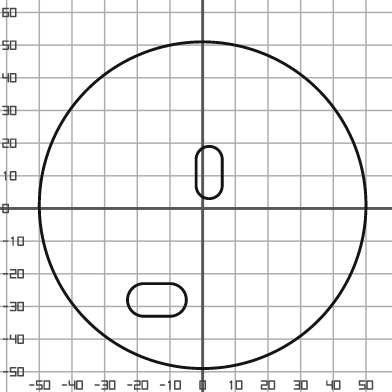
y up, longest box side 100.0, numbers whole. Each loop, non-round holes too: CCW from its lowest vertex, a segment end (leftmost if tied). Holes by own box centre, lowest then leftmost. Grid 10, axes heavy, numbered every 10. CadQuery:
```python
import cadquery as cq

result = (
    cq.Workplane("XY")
    .moveTo(0.0, 1.0)
    .circle(50.0)
    .moveTo(-18.0, -33.0)
    .lineTo(-10.0, -33.0)
    .threePointArc((-5.0, -28.0), (-10.0, -23.0))
    .lineTo(-18.0, -23.0)
    .threePointArc((-23.0, -28.0), (-18.0, -33.0))
    .close()
    .moveTo(-2.0, 7.0)
    .threePointArc((2.0, 3.0), (6.0, 7.0))
    .lineTo(6.0, 15.0)
    .threePointArc((2.0, 19.0), (-2.0, 15.0))
    .close()
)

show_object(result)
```